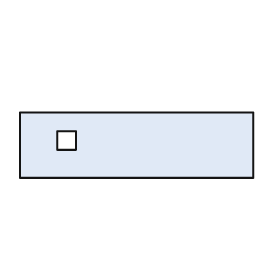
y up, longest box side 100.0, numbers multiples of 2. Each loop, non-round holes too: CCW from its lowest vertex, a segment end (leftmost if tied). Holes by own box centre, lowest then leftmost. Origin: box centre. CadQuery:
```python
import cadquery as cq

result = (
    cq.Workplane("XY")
    .moveTo(-50.0, -14.0)
    .lineTo(50.0, -14.0)
    .lineTo(50.0, 14.0)
    .lineTo(-50.0, 14.0)
    .close()
    .moveTo(-34.0, -2.0)
    .lineTo(-26.0, -2.0)
    .lineTo(-26.0, 6.0)
    .lineTo(-34.0, 6.0)
    .close()
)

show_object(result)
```